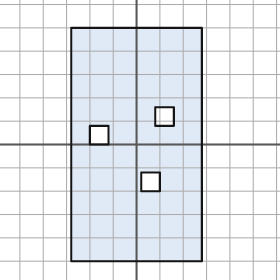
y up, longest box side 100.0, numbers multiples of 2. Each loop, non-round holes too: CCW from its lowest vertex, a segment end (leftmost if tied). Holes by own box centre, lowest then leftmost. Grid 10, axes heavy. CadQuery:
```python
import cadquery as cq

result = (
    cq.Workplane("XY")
    .moveTo(-28.0, -50.0)
    .lineTo(28.0, -50.0)
    .lineTo(28.0, 50.0)
    .lineTo(-28.0, 50.0)
    .close()
    .moveTo(2.0, -20.0)
    .lineTo(10.0, -20.0)
    .lineTo(10.0, -12.0)
    .lineTo(2.0, -12.0)
    .close()
    .moveTo(-20.0, 0.0)
    .lineTo(-12.0, 0.0)
    .lineTo(-12.0, 8.0)
    .lineTo(-20.0, 8.0)
    .close()
    .moveTo(8.0, 8.0)
    .lineTo(16.0, 8.0)
    .lineTo(16.0, 16.0)
    .lineTo(8.0, 16.0)
    .close()
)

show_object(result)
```